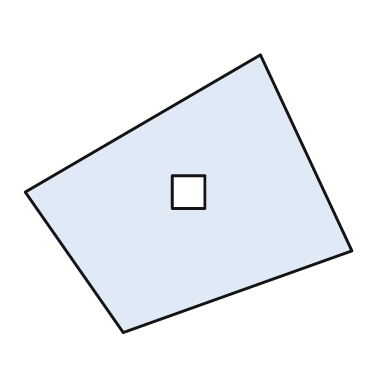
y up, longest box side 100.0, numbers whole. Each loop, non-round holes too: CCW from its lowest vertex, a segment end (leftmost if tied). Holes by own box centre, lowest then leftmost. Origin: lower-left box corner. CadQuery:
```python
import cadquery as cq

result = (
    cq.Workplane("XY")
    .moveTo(30.0, 0.0)
    .lineTo(100.0, 25.0)
    .lineTo(72.0, 85.0)
    .lineTo(0.0, 43.0)
    .close()
    .moveTo(45.0, 38.0)
    .lineTo(55.0, 38.0)
    .lineTo(55.0, 48.0)
    .lineTo(45.0, 48.0)
    .close()
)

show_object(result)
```